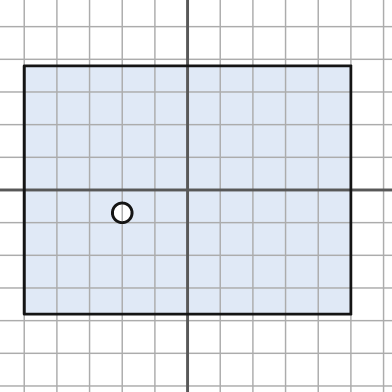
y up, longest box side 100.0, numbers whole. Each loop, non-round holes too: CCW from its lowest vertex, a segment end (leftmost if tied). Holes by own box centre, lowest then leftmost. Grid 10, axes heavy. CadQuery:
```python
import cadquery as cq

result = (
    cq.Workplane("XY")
    .moveTo(-50.0, -38.0)
    .lineTo(50.0, -38.0)
    .lineTo(50.0, 38.0)
    .lineTo(-50.0, 38.0)
    .close()
    .moveTo(-20.0, -7.0)
    .circle(3.0)
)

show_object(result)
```